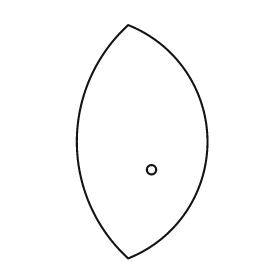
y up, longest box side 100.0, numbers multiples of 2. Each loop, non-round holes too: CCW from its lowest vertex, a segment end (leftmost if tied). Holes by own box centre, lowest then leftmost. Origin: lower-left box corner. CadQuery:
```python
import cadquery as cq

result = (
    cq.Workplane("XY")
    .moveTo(22.0, 0.0)
    .threePointArc((56.0, 50.0), (22.0, 100.0))
    .threePointArc((0.0, 50.0), (22.0, 0.0))
    .close()
    .moveTo(32.0, 38.0)
    .circle(2.0)
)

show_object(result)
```